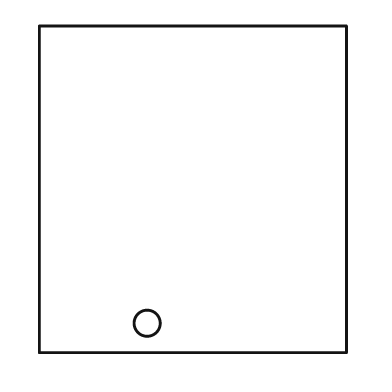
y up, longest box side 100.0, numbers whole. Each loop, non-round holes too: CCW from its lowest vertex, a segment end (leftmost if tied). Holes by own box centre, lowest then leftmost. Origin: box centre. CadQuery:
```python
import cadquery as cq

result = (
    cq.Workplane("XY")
    .moveTo(-47.0, -50.0)
    .lineTo(47.0, -50.0)
    .lineTo(47.0, 50.0)
    .lineTo(-47.0, 50.0)
    .close()
    .moveTo(-14.0, -41.0)
    .circle(4.0)
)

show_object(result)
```